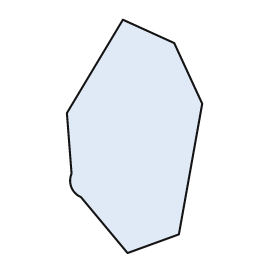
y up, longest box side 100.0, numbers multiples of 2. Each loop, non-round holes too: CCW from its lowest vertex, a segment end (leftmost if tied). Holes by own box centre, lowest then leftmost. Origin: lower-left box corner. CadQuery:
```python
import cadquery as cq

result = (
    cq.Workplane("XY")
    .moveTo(26.0, 0.0)
    .lineTo(48.0, 8.0)
    .lineTo(58.0, 64.0)
    .lineTo(46.0, 90.0)
    .lineTo(24.0, 100.0)
    .lineTo(0.0, 60.0)
    .lineTo(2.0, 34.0)
    .threePointArc((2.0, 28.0), (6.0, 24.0))
    .close()
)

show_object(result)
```